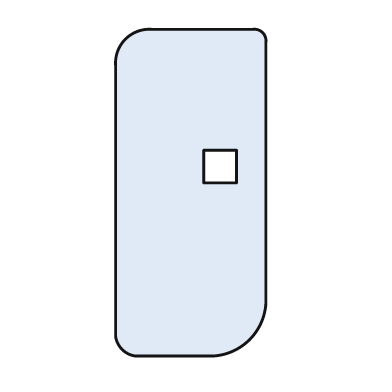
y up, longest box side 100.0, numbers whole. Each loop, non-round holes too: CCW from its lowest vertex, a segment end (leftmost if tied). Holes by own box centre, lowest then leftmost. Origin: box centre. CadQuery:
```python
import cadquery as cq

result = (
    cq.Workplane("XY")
    .moveTo(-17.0, -50.0)
    .lineTo(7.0, -50.0)
    .threePointArc((18.0, -45.0), (23.0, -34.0))
    .lineTo(23.0, 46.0)
    .threePointArc((22.0, 49.0), (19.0, 50.0))
    .lineTo(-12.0, 50.0)
    .threePointArc((-20.0, 47.0), (-23.0, 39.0))
    .lineTo(-23.0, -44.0)
    .threePointArc((-21.0, -48.0), (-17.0, -50.0))
    .close()
    .moveTo(4.0, 3.0)
    .lineTo(14.0, 3.0)
    .lineTo(14.0, 13.0)
    .lineTo(4.0, 13.0)
    .close()
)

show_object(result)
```